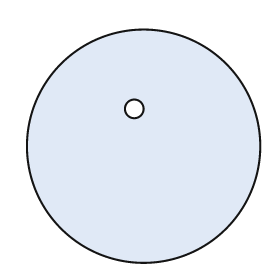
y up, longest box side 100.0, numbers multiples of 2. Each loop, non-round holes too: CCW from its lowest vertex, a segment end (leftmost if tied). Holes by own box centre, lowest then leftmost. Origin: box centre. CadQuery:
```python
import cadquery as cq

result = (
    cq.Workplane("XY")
    .moveTo(0.0, 0.0)
    .circle(50.0)
    .moveTo(-4.0, 16.0)
    .circle(4.0)
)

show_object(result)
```